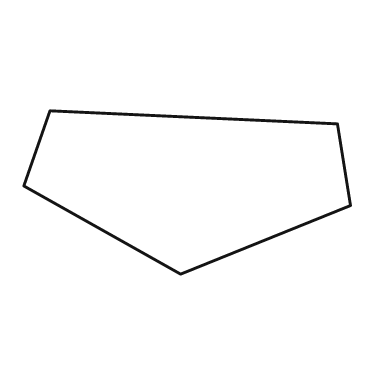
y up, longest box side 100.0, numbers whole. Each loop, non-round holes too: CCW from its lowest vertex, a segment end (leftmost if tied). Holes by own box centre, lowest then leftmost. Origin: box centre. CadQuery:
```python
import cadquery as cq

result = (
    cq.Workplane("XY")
    .moveTo(-2.0, -25.0)
    .lineTo(50.0, -4.0)
    .lineTo(46.0, 21.0)
    .lineTo(-42.0, 25.0)
    .lineTo(-50.0, 2.0)
    .close()
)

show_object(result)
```